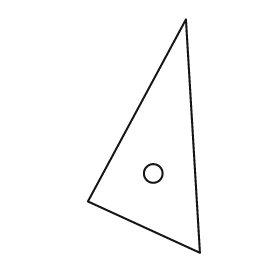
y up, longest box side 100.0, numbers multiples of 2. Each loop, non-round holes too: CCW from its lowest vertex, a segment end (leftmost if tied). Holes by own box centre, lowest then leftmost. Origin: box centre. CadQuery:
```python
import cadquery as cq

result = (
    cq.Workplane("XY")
    .moveTo(24.0, -50.0)
    .lineTo(18.0, 50.0)
    .lineTo(-24.0, -28.0)
    .close()
    .moveTo(4.0, -16.0)
    .circle(4.0)
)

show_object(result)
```